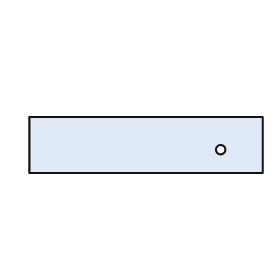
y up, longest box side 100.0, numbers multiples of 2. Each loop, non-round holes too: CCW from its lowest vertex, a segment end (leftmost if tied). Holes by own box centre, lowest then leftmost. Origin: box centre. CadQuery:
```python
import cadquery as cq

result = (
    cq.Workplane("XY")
    .moveTo(-50.0, -12.0)
    .lineTo(50.0, -12.0)
    .lineTo(50.0, 12.0)
    .lineTo(-50.0, 12.0)
    .close()
    .moveTo(32.0, -2.0)
    .circle(2.0)
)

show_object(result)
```